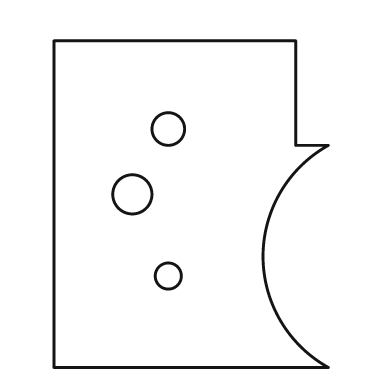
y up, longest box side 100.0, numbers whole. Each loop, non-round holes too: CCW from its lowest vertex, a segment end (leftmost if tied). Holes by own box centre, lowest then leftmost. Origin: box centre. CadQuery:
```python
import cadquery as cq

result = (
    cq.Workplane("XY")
    .moveTo(-42.0, -50.0)
    .lineTo(42.0, -50.0)
    .threePointArc((22.0, -16.0), (42.0, 18.0))
    .lineTo(32.0, 18.0)
    .lineTo(32.0, 50.0)
    .lineTo(-42.0, 50.0)
    .close()
    .moveTo(-7.0, -22.0)
    .circle(4.0)
    .moveTo(-18.0, 3.0)
    .circle(6.0)
    .moveTo(-7.0, 23.0)
    .circle(5.0)
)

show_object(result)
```